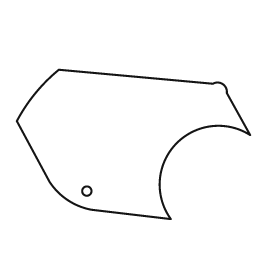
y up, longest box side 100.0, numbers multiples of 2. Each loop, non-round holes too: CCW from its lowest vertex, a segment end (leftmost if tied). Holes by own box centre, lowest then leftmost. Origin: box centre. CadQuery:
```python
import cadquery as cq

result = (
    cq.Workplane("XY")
    .moveTo(16.0, -32.0)
    .threePointArc((18.0, 0.0), (50.0, 4.0))
    .lineTo(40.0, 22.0)
    .threePointArc((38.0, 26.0), (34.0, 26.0))
    .lineTo(-32.0, 32.0)
    .threePointArc((-42.0, 22.0), (-50.0, 10.0))
    .lineTo(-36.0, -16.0)
    .threePointArc((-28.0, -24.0), (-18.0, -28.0))
    .close()
    .moveTo(-20.0, -20.0)
    .circle(2.0)
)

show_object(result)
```